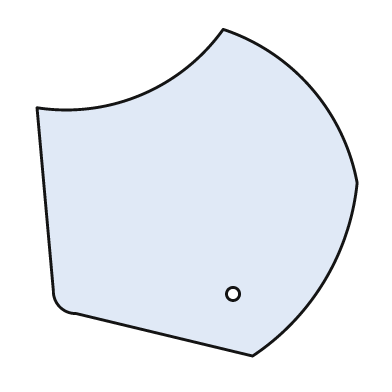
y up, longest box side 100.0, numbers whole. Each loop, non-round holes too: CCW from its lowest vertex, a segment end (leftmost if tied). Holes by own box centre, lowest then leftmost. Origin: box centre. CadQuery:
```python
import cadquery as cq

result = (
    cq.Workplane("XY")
    .moveTo(17.0, -50.0)
    .threePointArc((39.0, -27.0), (49.0, 3.0))
    .threePointArc((35.0, 32.0), (8.0, 50.0))
    .threePointArc((-17.0, 30.0), (-49.0, 26.0))
    .lineTo(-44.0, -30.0)
    .threePointArc((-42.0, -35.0), (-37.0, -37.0))
    .close()
    .moveTo(11.0, -31.0)
    .circle(2.0)
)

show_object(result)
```